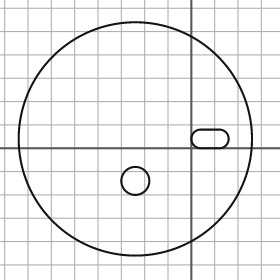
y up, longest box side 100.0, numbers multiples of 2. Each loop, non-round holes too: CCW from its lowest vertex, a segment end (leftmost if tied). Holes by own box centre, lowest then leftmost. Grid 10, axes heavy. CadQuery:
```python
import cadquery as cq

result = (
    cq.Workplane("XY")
    .moveTo(-24.0, 4.0)
    .circle(50.0)
    .moveTo(-24.0, -14.0)
    .circle(6.0)
    .moveTo(4.0, 0.0)
    .lineTo(12.0, 0.0)
    .threePointArc((16.0, 4.0), (12.0, 8.0))
    .lineTo(4.0, 8.0)
    .threePointArc((0.0, 4.0), (4.0, 0.0))
    .close()
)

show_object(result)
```